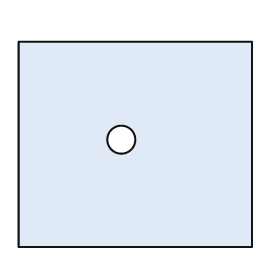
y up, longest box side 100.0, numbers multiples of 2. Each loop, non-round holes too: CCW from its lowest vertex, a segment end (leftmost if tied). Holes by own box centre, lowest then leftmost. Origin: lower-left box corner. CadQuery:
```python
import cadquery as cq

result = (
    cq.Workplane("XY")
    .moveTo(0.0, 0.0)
    .lineTo(100.0, 0.0)
    .lineTo(100.0, 88.0)
    .lineTo(0.0, 88.0)
    .close()
    .moveTo(44.0, 46.0)
    .circle(6.0)
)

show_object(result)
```